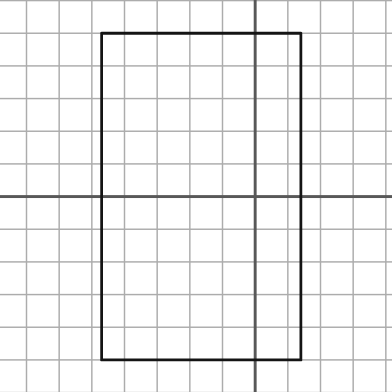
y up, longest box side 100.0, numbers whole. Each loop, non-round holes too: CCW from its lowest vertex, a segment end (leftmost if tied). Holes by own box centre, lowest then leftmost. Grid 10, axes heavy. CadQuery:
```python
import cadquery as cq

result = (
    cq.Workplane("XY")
    .moveTo(-47.0, -50.0)
    .lineTo(14.0, -50.0)
    .lineTo(14.0, 50.0)
    .lineTo(-47.0, 50.0)
    .close()
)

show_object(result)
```